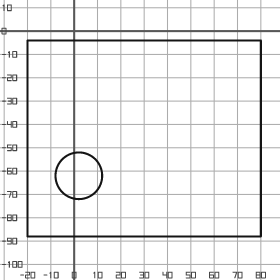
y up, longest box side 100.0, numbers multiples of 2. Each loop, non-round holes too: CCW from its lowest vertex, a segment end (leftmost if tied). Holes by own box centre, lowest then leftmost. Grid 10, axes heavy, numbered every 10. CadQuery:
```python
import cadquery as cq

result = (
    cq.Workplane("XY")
    .moveTo(-20.0, -88.0)
    .lineTo(80.0, -88.0)
    .lineTo(80.0, -4.0)
    .lineTo(-20.0, -4.0)
    .close()
    .moveTo(2.0, -62.0)
    .circle(10.0)
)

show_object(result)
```